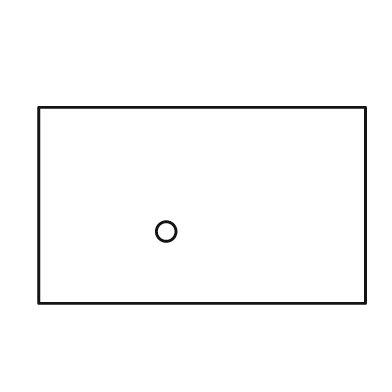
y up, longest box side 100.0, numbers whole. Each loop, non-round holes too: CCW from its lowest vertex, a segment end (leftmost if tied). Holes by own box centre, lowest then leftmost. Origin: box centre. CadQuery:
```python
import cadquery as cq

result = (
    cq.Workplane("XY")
    .moveTo(-50.0, -30.0)
    .lineTo(50.0, -30.0)
    .lineTo(50.0, 30.0)
    .lineTo(-50.0, 30.0)
    .close()
    .moveTo(-11.0, -8.0)
    .circle(3.0)
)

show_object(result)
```